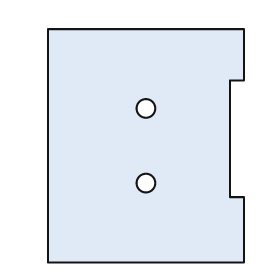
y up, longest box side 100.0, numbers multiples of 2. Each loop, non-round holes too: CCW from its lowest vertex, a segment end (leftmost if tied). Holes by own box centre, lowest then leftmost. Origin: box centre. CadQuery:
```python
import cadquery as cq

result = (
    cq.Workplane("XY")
    .moveTo(-42.0, -50.0)
    .lineTo(42.0, -50.0)
    .lineTo(42.0, -22.0)
    .lineTo(36.0, -22.0)
    .lineTo(36.0, 28.0)
    .lineTo(42.0, 28.0)
    .lineTo(42.0, 50.0)
    .lineTo(-42.0, 50.0)
    .close()
    .moveTo(0.0, -16.0)
    .circle(4.0)
    .moveTo(0.0, 16.0)
    .circle(4.0)
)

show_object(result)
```